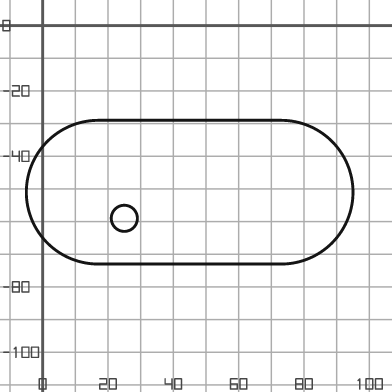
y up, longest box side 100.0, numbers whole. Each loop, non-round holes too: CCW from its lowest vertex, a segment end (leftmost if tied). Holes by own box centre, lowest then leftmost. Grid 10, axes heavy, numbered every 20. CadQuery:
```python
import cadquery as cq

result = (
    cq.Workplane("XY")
    .moveTo(17.0, -73.0)
    .lineTo(73.0, -73.0)
    .threePointArc((95.0, -51.0), (73.0, -29.0))
    .lineTo(17.0, -29.0)
    .threePointArc((-5.0, -51.0), (17.0, -73.0))
    .close()
    .moveTo(25.0, -59.0)
    .circle(4.0)
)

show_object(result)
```